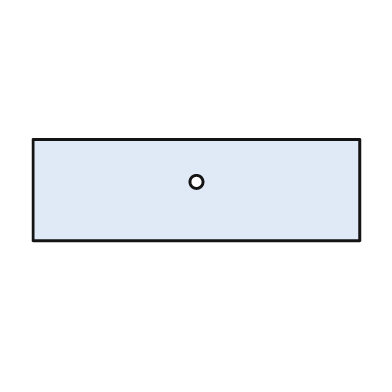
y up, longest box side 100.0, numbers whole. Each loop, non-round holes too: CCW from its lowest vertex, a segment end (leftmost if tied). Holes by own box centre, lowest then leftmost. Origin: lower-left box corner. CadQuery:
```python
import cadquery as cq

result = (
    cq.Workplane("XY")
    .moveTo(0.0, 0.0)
    .lineTo(100.0, 0.0)
    .lineTo(100.0, 31.0)
    .lineTo(0.0, 31.0)
    .close()
    .moveTo(50.0, 18.0)
    .circle(2.0)
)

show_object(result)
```